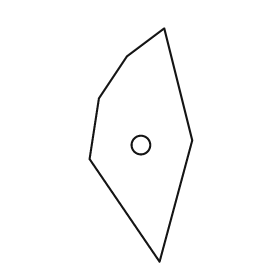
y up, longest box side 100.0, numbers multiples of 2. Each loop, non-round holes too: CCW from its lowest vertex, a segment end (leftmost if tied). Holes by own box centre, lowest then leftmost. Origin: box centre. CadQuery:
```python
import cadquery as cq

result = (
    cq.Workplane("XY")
    .moveTo(8.0, -50.0)
    .lineTo(22.0, 2.0)
    .lineTo(10.0, 50.0)
    .lineTo(-6.0, 38.0)
    .lineTo(-18.0, 20.0)
    .lineTo(-22.0, -6.0)
    .close()
    .moveTo(0.0, 0.0)
    .circle(4.0)
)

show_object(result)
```